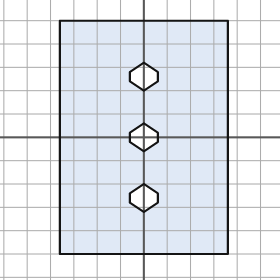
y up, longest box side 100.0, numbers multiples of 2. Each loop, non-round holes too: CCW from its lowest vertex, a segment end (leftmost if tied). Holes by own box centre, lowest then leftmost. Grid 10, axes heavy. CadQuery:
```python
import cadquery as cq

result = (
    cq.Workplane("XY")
    .moveTo(-36.0, -50.0)
    .lineTo(36.0, -50.0)
    .lineTo(36.0, 50.0)
    .lineTo(-36.0, 50.0)
    .close()
    .moveTo(0.0, -32.0)
    .lineTo(6.0, -28.0)
    .lineTo(6.0, -24.0)
    .lineTo(0.0, -20.0)
    .lineTo(-6.0, -24.0)
    .lineTo(-6.0, -28.0)
    .close()
    .moveTo(0.0, -6.0)
    .lineTo(6.0, -2.0)
    .lineTo(6.0, 2.0)
    .lineTo(0.0, 6.0)
    .lineTo(-6.0, 2.0)
    .lineTo(-6.0, -2.0)
    .close()
    .moveTo(0.0, 20.0)
    .lineTo(6.0, 24.0)
    .lineTo(6.0, 28.0)
    .lineTo(0.0, 32.0)
    .lineTo(-6.0, 28.0)
    .lineTo(-6.0, 24.0)
    .close()
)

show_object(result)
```